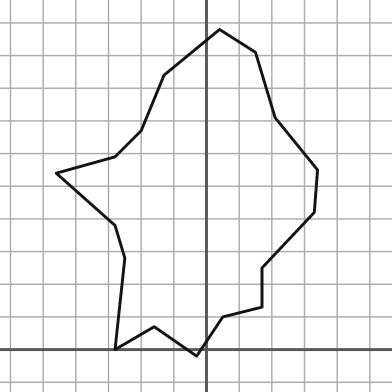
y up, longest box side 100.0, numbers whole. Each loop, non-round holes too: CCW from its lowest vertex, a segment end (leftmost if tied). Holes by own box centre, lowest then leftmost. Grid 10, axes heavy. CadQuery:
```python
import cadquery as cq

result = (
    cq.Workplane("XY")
    .moveTo(-3.0, -2.0)
    .lineTo(5.0, 10.0)
    .lineTo(17.0, 13.0)
    .lineTo(17.0, 25.0)
    .lineTo(33.0, 42.0)
    .lineTo(34.0, 55.0)
    .lineTo(21.0, 71.0)
    .lineTo(15.0, 91.0)
    .lineTo(4.0, 98.0)
    .lineTo(-13.0, 84.0)
    .lineTo(-20.0, 67.0)
    .lineTo(-28.0, 59.0)
    .lineTo(-46.0, 54.0)
    .lineTo(-28.0, 38.0)
    .lineTo(-25.0, 28.0)
    .lineTo(-28.0, 0.0)
    .lineTo(-16.0, 7.0)
    .close()
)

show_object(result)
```